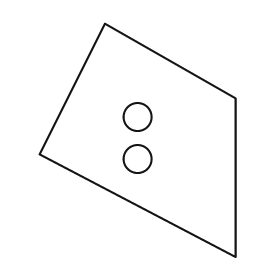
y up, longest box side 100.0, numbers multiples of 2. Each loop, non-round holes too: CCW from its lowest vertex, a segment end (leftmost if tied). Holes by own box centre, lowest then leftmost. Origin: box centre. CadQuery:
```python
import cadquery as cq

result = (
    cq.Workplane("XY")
    .moveTo(42.0, -50.0)
    .lineTo(42.0, 18.0)
    .lineTo(-14.0, 50.0)
    .lineTo(-42.0, -6.0)
    .close()
    .moveTo(0.0, -8.0)
    .circle(6.0)
    .moveTo(0.0, 10.0)
    .circle(6.0)
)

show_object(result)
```